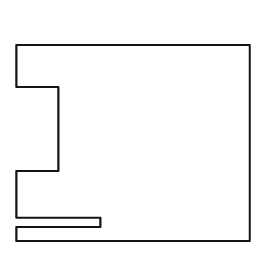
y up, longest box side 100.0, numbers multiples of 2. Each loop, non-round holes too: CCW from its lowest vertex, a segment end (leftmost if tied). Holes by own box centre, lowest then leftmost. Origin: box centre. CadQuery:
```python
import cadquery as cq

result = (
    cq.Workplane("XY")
    .moveTo(-50.0, -42.0)
    .lineTo(50.0, -42.0)
    .lineTo(50.0, 42.0)
    .lineTo(-50.0, 42.0)
    .lineTo(-50.0, 24.0)
    .lineTo(-32.0, 24.0)
    .lineTo(-32.0, -12.0)
    .lineTo(-50.0, -12.0)
    .lineTo(-50.0, -32.0)
    .lineTo(-14.0, -32.0)
    .lineTo(-14.0, -36.0)
    .lineTo(-50.0, -36.0)
    .close()
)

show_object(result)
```